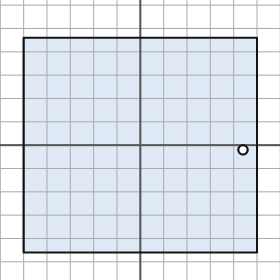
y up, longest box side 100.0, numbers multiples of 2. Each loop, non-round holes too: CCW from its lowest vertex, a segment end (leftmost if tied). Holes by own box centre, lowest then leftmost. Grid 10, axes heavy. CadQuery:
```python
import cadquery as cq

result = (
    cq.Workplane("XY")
    .moveTo(-50.0, -46.0)
    .lineTo(50.0, -46.0)
    .lineTo(50.0, 46.0)
    .lineTo(-50.0, 46.0)
    .close()
    .moveTo(44.0, -2.0)
    .circle(2.0)
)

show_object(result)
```